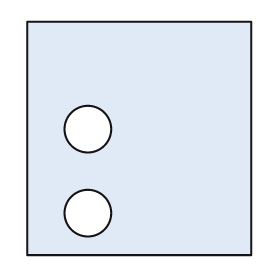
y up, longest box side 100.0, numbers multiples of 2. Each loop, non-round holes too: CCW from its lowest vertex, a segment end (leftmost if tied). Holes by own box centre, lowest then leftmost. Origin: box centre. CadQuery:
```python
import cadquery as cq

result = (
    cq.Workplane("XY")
    .moveTo(-48.0, -50.0)
    .lineTo(48.0, -50.0)
    .lineTo(48.0, 50.0)
    .lineTo(-48.0, 50.0)
    .close()
    .moveTo(-22.0, -32.0)
    .circle(10.0)
    .moveTo(-22.0, 4.0)
    .circle(10.0)
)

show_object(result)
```